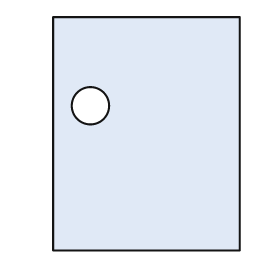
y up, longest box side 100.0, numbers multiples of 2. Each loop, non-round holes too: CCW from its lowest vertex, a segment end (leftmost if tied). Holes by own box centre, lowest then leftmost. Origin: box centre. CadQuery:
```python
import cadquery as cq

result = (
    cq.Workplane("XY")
    .moveTo(-40.0, -50.0)
    .lineTo(40.0, -50.0)
    .lineTo(40.0, 50.0)
    .lineTo(-40.0, 50.0)
    .close()
    .moveTo(-24.0, 12.0)
    .circle(8.0)
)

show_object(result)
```